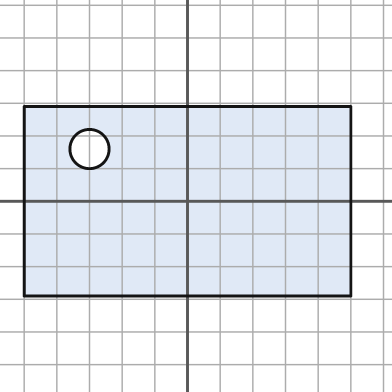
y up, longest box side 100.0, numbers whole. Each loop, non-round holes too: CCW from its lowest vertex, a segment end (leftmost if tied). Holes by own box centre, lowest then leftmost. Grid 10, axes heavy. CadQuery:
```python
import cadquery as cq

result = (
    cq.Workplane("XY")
    .moveTo(-50.0, -29.0)
    .lineTo(50.0, -29.0)
    .lineTo(50.0, 29.0)
    .lineTo(-50.0, 29.0)
    .close()
    .moveTo(-30.0, 16.0)
    .circle(6.0)
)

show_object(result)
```